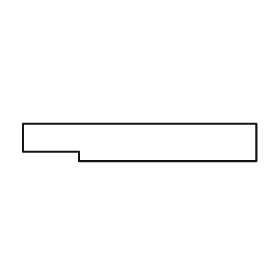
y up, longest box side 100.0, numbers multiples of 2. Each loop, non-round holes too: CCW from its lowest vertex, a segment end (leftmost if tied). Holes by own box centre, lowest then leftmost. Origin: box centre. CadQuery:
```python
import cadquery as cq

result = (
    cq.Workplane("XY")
    .moveTo(-26.0, -8.0)
    .lineTo(50.0, -8.0)
    .lineTo(50.0, 8.0)
    .lineTo(-50.0, 8.0)
    .lineTo(-50.0, -4.0)
    .lineTo(-26.0, -4.0)
    .close()
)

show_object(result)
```